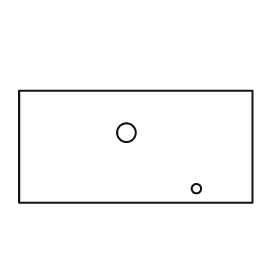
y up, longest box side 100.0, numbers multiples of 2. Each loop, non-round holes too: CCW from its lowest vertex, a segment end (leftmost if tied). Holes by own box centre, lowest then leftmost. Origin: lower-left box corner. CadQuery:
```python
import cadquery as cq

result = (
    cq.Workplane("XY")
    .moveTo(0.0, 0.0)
    .lineTo(100.0, 0.0)
    .lineTo(100.0, 48.0)
    .lineTo(0.0, 48.0)
    .close()
    .moveTo(76.0, 6.0)
    .circle(2.0)
    .moveTo(46.0, 30.0)
    .circle(4.0)
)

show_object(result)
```